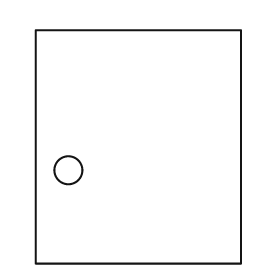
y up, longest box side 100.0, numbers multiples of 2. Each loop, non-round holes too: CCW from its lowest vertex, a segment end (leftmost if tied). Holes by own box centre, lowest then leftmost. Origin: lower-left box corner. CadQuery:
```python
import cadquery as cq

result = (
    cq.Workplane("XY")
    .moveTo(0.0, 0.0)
    .lineTo(88.0, 0.0)
    .lineTo(88.0, 100.0)
    .lineTo(0.0, 100.0)
    .close()
    .moveTo(14.0, 40.0)
    .circle(6.0)
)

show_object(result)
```